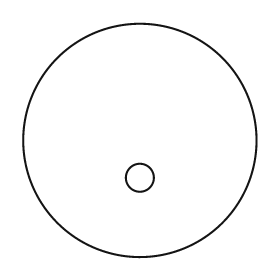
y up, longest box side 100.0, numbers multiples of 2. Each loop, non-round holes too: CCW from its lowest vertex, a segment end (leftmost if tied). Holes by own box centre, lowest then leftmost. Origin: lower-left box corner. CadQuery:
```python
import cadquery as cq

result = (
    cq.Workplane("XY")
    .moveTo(50.0, 50.0)
    .circle(50.0)
    .moveTo(50.0, 34.0)
    .circle(6.0)
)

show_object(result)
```